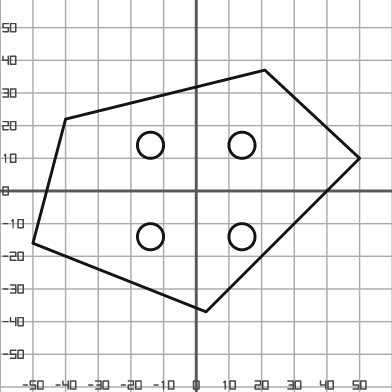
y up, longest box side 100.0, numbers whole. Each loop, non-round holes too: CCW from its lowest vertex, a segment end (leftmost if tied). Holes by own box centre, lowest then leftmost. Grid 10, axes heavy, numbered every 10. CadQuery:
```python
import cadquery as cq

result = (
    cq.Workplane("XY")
    .moveTo(3.0, -37.0)
    .lineTo(50.0, 10.0)
    .lineTo(21.0, 37.0)
    .lineTo(-40.0, 22.0)
    .lineTo(-50.0, -16.0)
    .close()
    .moveTo(-14.0, -14.0)
    .circle(4.0)
    .moveTo(14.0, -14.0)
    .circle(4.0)
    .moveTo(-14.0, 14.0)
    .circle(4.0)
    .moveTo(14.0, 14.0)
    .circle(4.0)
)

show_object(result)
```